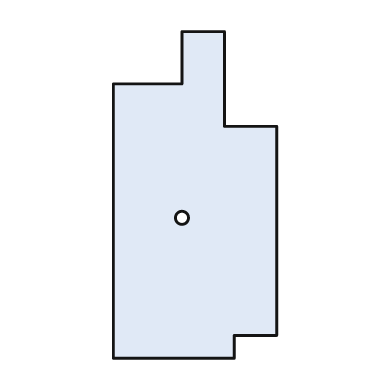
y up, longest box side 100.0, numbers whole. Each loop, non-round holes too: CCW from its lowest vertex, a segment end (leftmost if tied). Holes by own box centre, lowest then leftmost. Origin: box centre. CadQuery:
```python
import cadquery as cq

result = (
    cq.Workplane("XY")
    .moveTo(-25.0, -50.0)
    .lineTo(12.0, -50.0)
    .lineTo(12.0, -43.0)
    .lineTo(25.0, -43.0)
    .lineTo(25.0, 21.0)
    .lineTo(9.0, 21.0)
    .lineTo(9.0, 50.0)
    .lineTo(-4.0, 50.0)
    .lineTo(-4.0, 34.0)
    .lineTo(-25.0, 34.0)
    .close()
    .moveTo(-4.0, -7.0)
    .circle(2.0)
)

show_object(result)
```